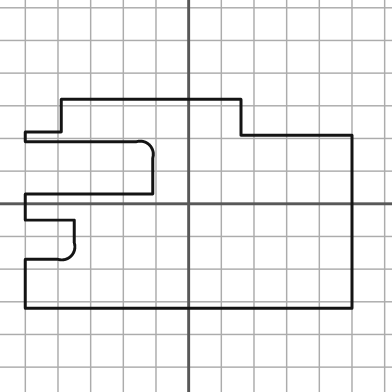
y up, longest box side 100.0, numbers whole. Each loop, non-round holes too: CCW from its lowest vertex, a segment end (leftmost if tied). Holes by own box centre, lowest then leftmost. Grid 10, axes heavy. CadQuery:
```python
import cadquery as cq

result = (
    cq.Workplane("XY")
    .moveTo(-50.0, -32.0)
    .lineTo(50.0, -32.0)
    .lineTo(50.0, 21.0)
    .lineTo(16.0, 21.0)
    .lineTo(16.0, 32.0)
    .lineTo(-39.0, 32.0)
    .lineTo(-39.0, 22.0)
    .lineTo(-50.0, 22.0)
    .lineTo(-50.0, 19.0)
    .lineTo(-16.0, 19.0)
    .threePointArc((-12.0, 18.0), (-11.0, 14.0))
    .lineTo(-11.0, 3.0)
    .lineTo(-50.0, 3.0)
    .lineTo(-50.0, -5.0)
    .lineTo(-35.0, -5.0)
    .lineTo(-35.0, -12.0)
    .threePointArc((-36.0, -16.0), (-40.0, -17.0))
    .lineTo(-50.0, -17.0)
    .close()
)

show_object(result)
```